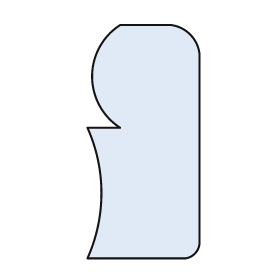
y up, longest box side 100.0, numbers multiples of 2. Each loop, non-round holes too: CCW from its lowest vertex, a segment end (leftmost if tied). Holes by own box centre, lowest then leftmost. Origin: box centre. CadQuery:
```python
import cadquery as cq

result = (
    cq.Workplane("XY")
    .moveTo(-24.0, -50.0)
    .lineTo(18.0, -50.0)
    .threePointArc((22.0, -48.0), (24.0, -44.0))
    .lineTo(24.0, 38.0)
    .threePointArc((20.0, 46.0), (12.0, 50.0))
    .lineTo(-10.0, 50.0)
    .threePointArc((-22.0, 28.0), (-10.0, 6.0))
    .lineTo(-24.0, 6.0)
    .threePointArc((-18.0, -22.0), (-24.0, -50.0))
    .close()
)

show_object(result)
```